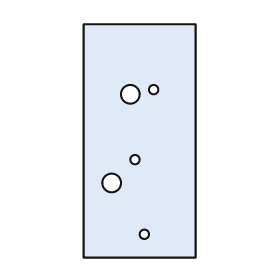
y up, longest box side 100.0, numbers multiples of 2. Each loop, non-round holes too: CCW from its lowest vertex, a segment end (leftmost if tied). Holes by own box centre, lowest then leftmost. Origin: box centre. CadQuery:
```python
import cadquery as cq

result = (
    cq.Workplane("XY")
    .moveTo(-24.0, -50.0)
    .lineTo(24.0, -50.0)
    .lineTo(24.0, 50.0)
    .lineTo(-24.0, 50.0)
    .close()
    .moveTo(2.0, -40.0)
    .circle(2.0)
    .moveTo(-12.0, -18.0)
    .circle(4.0)
    .moveTo(-2.0, -8.0)
    .circle(2.0)
    .moveTo(-4.0, 20.0)
    .circle(4.0)
    .moveTo(6.0, 22.0)
    .circle(2.0)
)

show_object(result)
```